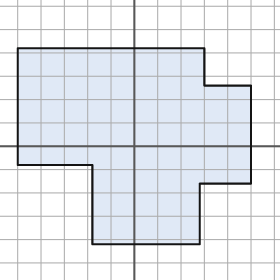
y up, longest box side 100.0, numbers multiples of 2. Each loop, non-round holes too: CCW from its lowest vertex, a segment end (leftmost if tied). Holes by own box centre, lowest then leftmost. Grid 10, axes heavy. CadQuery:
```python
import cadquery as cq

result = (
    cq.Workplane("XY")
    .moveTo(-18.0, -42.0)
    .lineTo(28.0, -42.0)
    .lineTo(28.0, -16.0)
    .lineTo(50.0, -16.0)
    .lineTo(50.0, 26.0)
    .lineTo(30.0, 26.0)
    .lineTo(30.0, 42.0)
    .lineTo(-50.0, 42.0)
    .lineTo(-50.0, -8.0)
    .lineTo(-18.0, -8.0)
    .close()
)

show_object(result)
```